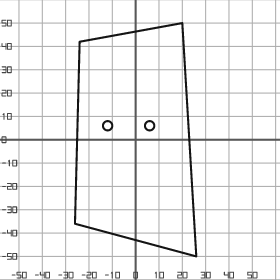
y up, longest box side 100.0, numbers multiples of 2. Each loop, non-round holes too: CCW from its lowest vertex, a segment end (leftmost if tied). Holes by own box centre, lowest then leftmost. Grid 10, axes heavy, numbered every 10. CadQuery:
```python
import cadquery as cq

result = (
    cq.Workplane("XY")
    .moveTo(26.0, -50.0)
    .lineTo(20.0, 50.0)
    .lineTo(-24.0, 42.0)
    .lineTo(-26.0, -36.0)
    .close()
    .moveTo(-12.0, 6.0)
    .circle(2.0)
    .moveTo(6.0, 6.0)
    .circle(2.0)
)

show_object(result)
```